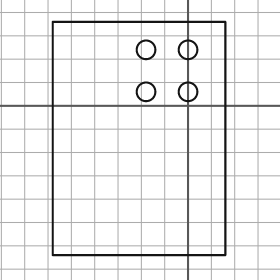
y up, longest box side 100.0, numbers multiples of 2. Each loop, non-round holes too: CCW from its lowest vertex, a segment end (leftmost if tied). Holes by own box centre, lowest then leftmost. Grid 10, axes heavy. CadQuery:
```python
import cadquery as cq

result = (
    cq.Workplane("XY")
    .moveTo(-58.0, -64.0)
    .lineTo(16.0, -64.0)
    .lineTo(16.0, 36.0)
    .lineTo(-58.0, 36.0)
    .close()
    .moveTo(-18.0, 6.0)
    .circle(4.0)
    .moveTo(0.0, 6.0)
    .circle(4.0)
    .moveTo(-18.0, 24.0)
    .circle(4.0)
    .moveTo(0.0, 24.0)
    .circle(4.0)
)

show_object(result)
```